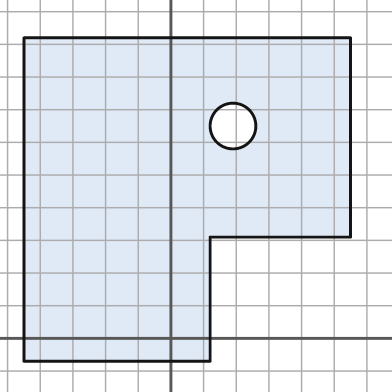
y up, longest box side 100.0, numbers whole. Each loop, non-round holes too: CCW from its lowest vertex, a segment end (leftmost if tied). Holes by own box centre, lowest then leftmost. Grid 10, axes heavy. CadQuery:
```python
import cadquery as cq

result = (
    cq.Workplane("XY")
    .moveTo(-45.0, -7.0)
    .lineTo(12.0, -7.0)
    .lineTo(12.0, 31.0)
    .lineTo(55.0, 31.0)
    .lineTo(55.0, 92.0)
    .lineTo(-45.0, 92.0)
    .close()
    .moveTo(19.0, 65.0)
    .circle(7.0)
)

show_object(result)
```